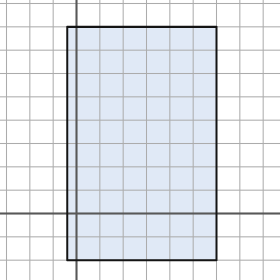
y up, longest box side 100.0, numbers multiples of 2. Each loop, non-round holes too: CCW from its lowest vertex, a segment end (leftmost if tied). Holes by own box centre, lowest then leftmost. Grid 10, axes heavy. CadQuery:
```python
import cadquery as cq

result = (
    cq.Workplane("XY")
    .moveTo(-4.0, -20.0)
    .lineTo(60.0, -20.0)
    .lineTo(60.0, 80.0)
    .lineTo(-4.0, 80.0)
    .close()
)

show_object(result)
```